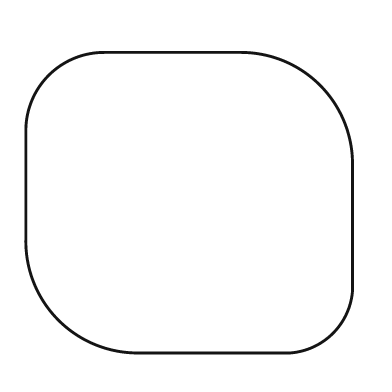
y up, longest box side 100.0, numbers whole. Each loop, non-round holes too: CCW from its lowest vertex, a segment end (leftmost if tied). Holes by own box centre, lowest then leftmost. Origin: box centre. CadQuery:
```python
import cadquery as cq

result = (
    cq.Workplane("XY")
    .moveTo(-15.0, -46.0)
    .lineTo(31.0, -46.0)
    .threePointArc((44.0, -40.0), (50.0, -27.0))
    .lineTo(50.0, 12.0)
    .threePointArc((40.0, 36.0), (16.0, 46.0))
    .lineTo(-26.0, 46.0)
    .threePointArc((-43.0, 39.0), (-50.0, 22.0))
    .lineTo(-50.0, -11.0)
    .threePointArc((-40.0, -36.0), (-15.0, -46.0))
    .close()
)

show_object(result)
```